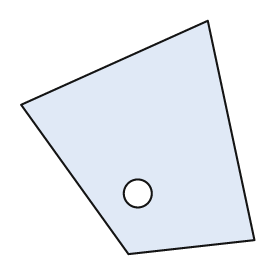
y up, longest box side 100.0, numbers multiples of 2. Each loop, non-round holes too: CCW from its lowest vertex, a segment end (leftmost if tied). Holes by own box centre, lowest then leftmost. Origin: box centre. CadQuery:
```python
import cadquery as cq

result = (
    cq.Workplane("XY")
    .moveTo(-4.0, -50.0)
    .lineTo(50.0, -44.0)
    .lineTo(30.0, 50.0)
    .lineTo(-50.0, 14.0)
    .close()
    .moveTo(0.0, -24.0)
    .circle(6.0)
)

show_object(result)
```